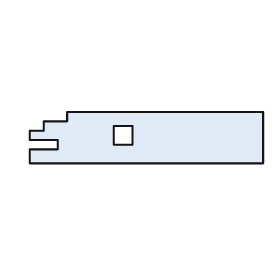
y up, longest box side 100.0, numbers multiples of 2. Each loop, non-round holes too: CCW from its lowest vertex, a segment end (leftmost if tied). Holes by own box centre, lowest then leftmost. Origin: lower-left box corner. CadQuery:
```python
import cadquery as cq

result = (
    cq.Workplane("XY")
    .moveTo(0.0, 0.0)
    .lineTo(100.0, 0.0)
    .lineTo(100.0, 22.0)
    .lineTo(16.0, 22.0)
    .lineTo(16.0, 18.0)
    .lineTo(6.0, 18.0)
    .lineTo(6.0, 14.0)
    .lineTo(0.0, 14.0)
    .lineTo(0.0, 10.0)
    .lineTo(12.0, 10.0)
    .lineTo(12.0, 6.0)
    .lineTo(0.0, 6.0)
    .close()
    .moveTo(36.0, 8.0)
    .lineTo(44.0, 8.0)
    .lineTo(44.0, 16.0)
    .lineTo(36.0, 16.0)
    .close()
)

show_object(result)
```